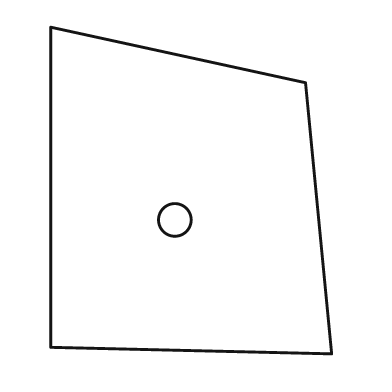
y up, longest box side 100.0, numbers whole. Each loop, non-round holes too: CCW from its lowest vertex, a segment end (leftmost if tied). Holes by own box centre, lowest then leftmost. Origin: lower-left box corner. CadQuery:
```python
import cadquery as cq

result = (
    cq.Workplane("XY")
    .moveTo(86.0, 0.0)
    .lineTo(78.0, 83.0)
    .lineTo(0.0, 100.0)
    .lineTo(0.0, 2.0)
    .close()
    .moveTo(38.0, 41.0)
    .circle(5.0)
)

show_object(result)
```